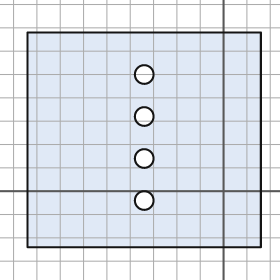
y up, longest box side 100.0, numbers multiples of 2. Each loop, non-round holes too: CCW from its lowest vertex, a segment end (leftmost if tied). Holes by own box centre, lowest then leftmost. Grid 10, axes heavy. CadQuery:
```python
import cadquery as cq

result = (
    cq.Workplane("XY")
    .moveTo(-84.0, -24.0)
    .lineTo(16.0, -24.0)
    .lineTo(16.0, 68.0)
    .lineTo(-84.0, 68.0)
    .close()
    .moveTo(-34.0, -4.0)
    .circle(4.0)
    .moveTo(-34.0, 14.0)
    .circle(4.0)
    .moveTo(-34.0, 32.0)
    .circle(4.0)
    .moveTo(-34.0, 50.0)
    .circle(4.0)
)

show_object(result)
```